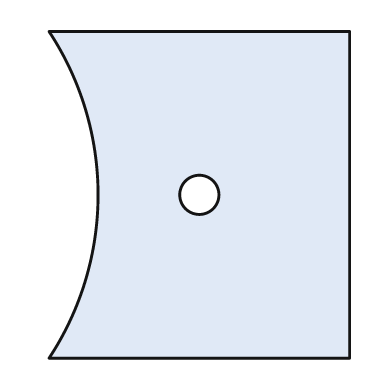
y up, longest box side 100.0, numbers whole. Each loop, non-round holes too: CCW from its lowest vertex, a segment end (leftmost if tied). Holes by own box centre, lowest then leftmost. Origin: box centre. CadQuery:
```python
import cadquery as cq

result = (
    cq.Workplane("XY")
    .moveTo(-46.0, -50.0)
    .lineTo(46.0, -50.0)
    .lineTo(46.0, 50.0)
    .lineTo(-46.0, 50.0)
    .threePointArc((-31.0, 0.0), (-46.0, -50.0))
    .close()
    .moveTo(0.0, 0.0)
    .circle(6.0)
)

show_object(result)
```